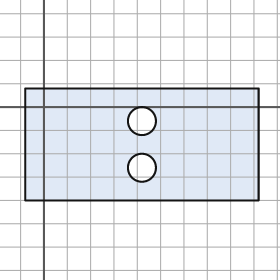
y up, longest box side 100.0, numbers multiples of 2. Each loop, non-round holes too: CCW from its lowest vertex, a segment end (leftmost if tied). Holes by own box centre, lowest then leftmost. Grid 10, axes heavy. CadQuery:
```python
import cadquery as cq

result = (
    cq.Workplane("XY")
    .moveTo(-8.0, -40.0)
    .lineTo(92.0, -40.0)
    .lineTo(92.0, 8.0)
    .lineTo(-8.0, 8.0)
    .close()
    .moveTo(42.0, -26.0)
    .circle(6.0)
    .moveTo(42.0, -6.0)
    .circle(6.0)
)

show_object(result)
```